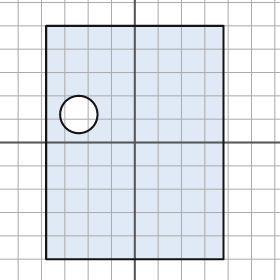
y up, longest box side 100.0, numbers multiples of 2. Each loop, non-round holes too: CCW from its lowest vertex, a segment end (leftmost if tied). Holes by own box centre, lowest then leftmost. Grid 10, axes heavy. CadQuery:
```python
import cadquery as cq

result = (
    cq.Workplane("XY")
    .moveTo(-38.0, -50.0)
    .lineTo(38.0, -50.0)
    .lineTo(38.0, 50.0)
    .lineTo(-38.0, 50.0)
    .close()
    .moveTo(-24.0, 12.0)
    .circle(8.0)
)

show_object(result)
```